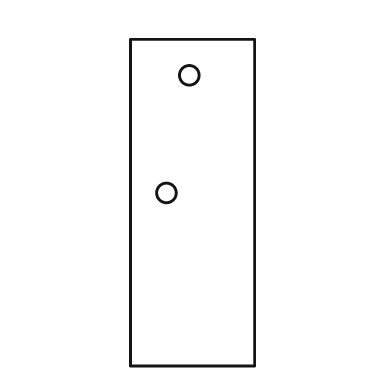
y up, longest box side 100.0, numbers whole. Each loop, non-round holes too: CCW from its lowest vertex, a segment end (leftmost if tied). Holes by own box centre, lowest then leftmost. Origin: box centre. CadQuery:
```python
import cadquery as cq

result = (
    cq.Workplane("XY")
    .moveTo(-19.0, -50.0)
    .lineTo(19.0, -50.0)
    .lineTo(19.0, 50.0)
    .lineTo(-19.0, 50.0)
    .close()
    .moveTo(-8.0, 3.0)
    .circle(3.0)
    .moveTo(-1.0, 39.0)
    .circle(3.0)
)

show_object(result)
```